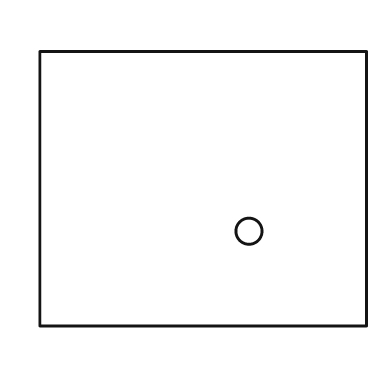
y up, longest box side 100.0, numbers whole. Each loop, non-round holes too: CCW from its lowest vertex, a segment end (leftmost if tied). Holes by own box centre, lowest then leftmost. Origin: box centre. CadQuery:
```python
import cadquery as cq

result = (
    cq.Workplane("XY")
    .moveTo(-50.0, -42.0)
    .lineTo(50.0, -42.0)
    .lineTo(50.0, 42.0)
    .lineTo(-50.0, 42.0)
    .close()
    .moveTo(14.0, -13.0)
    .circle(4.0)
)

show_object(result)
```